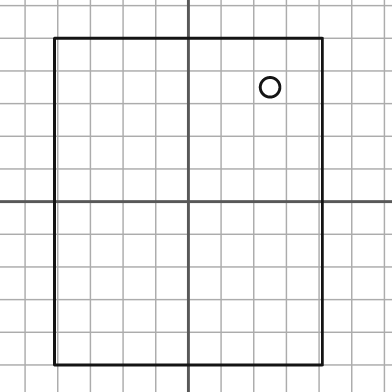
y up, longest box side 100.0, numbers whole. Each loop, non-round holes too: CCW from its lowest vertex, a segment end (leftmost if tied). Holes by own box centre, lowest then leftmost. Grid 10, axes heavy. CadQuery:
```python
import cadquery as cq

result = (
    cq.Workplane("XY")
    .moveTo(-41.0, -50.0)
    .lineTo(41.0, -50.0)
    .lineTo(41.0, 50.0)
    .lineTo(-41.0, 50.0)
    .close()
    .moveTo(25.0, 35.0)
    .circle(3.0)
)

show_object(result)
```